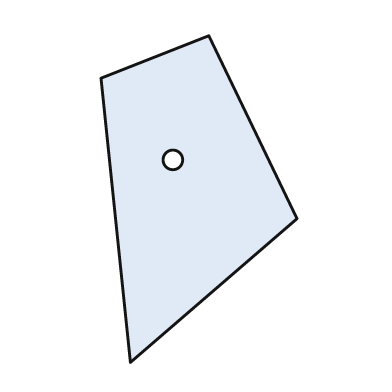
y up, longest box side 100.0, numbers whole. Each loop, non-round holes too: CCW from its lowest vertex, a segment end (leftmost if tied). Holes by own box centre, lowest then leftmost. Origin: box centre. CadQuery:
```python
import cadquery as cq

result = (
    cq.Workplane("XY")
    .moveTo(-21.0, -50.0)
    .lineTo(30.0, -6.0)
    .lineTo(3.0, 50.0)
    .lineTo(-30.0, 37.0)
    .close()
    .moveTo(-8.0, 12.0)
    .circle(3.0)
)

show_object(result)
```